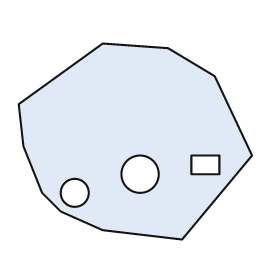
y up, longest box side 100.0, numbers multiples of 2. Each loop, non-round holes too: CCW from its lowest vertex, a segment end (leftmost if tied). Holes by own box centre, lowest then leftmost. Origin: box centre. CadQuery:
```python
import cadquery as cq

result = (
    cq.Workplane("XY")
    .moveTo(20.0, -42.0)
    .lineTo(50.0, -6.0)
    .lineTo(34.0, 28.0)
    .lineTo(14.0, 40.0)
    .lineTo(-14.0, 42.0)
    .lineTo(-50.0, 16.0)
    .lineTo(-48.0, -2.0)
    .lineTo(-40.0, -22.0)
    .lineTo(-32.0, -30.0)
    .lineTo(-14.0, -38.0)
    .close()
    .moveTo(-26.0, -22.0)
    .circle(6.0)
    .moveTo(2.0, -14.0)
    .circle(8.0)
    .moveTo(24.0, -14.0)
    .lineTo(36.0, -14.0)
    .lineTo(36.0, -6.0)
    .lineTo(24.0, -6.0)
    .close()
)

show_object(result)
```